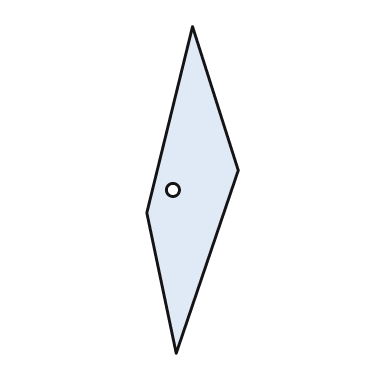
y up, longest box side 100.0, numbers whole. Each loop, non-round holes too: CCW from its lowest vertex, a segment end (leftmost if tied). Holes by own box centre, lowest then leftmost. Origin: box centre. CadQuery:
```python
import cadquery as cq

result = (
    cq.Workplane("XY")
    .moveTo(-5.0, -50.0)
    .lineTo(14.0, 6.0)
    .lineTo(0.0, 50.0)
    .lineTo(-14.0, -7.0)
    .close()
    .moveTo(-6.0, 0.0)
    .circle(2.0)
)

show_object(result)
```